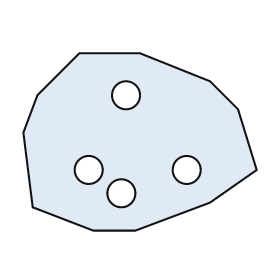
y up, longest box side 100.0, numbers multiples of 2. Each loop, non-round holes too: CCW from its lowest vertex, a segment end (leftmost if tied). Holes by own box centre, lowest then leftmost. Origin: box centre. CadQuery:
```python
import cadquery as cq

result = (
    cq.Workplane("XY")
    .moveTo(-20.0, -38.0)
    .lineTo(-2.0, -38.0)
    .lineTo(30.0, -26.0)
    .lineTo(50.0, -12.0)
    .lineTo(42.0, 14.0)
    .lineTo(30.0, 26.0)
    .lineTo(0.0, 38.0)
    .lineTo(-26.0, 38.0)
    .lineTo(-44.0, 20.0)
    .lineTo(-50.0, 4.0)
    .lineTo(-46.0, -28.0)
    .close()
    .moveTo(-8.0, -22.0)
    .circle(6.0)
    .moveTo(-22.0, -12.0)
    .circle(6.0)
    .moveTo(20.0, -12.0)
    .circle(6.0)
    .moveTo(-6.0, 20.0)
    .circle(6.0)
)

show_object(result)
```